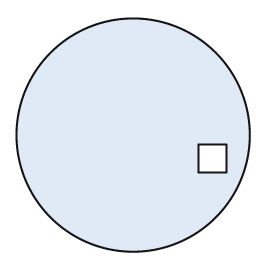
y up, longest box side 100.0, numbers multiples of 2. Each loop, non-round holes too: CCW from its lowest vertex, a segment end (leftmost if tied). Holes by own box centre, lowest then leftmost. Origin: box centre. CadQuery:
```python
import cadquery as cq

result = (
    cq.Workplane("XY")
    .moveTo(0.0, 0.0)
    .circle(50.0)
    .moveTo(28.0, -16.0)
    .lineTo(40.0, -16.0)
    .lineTo(40.0, -4.0)
    .lineTo(28.0, -4.0)
    .close()
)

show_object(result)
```